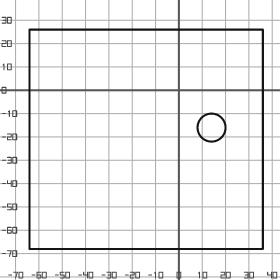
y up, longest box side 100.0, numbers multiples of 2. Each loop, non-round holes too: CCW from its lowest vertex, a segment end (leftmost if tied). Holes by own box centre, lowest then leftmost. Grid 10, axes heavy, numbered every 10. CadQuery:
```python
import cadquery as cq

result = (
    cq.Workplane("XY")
    .moveTo(-64.0, -68.0)
    .lineTo(36.0, -68.0)
    .lineTo(36.0, 26.0)
    .lineTo(-64.0, 26.0)
    .close()
    .moveTo(14.0, -16.0)
    .circle(6.0)
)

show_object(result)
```